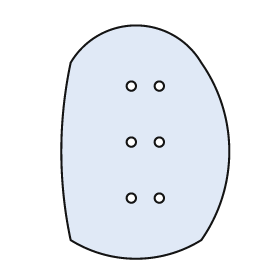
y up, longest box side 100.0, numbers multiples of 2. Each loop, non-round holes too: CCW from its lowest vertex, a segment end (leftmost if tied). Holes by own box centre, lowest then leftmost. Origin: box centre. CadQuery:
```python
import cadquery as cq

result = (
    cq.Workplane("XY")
    .moveTo(-32.0, -42.0)
    .threePointArc((-4.0, -50.0), (24.0, -42.0))
    .threePointArc((36.0, -4.0), (24.0, 34.0))
    .threePointArc((-4.0, 50.0), (-32.0, 34.0))
    .threePointArc((-36.0, -4.0), (-32.0, -42.0))
    .close()
    .moveTo(-6.0, -24.0)
    .circle(2.0)
    .moveTo(6.0, -24.0)
    .circle(2.0)
    .moveTo(-6.0, 0.0)
    .circle(2.0)
    .moveTo(6.0, 0.0)
    .circle(2.0)
    .moveTo(-6.0, 24.0)
    .circle(2.0)
    .moveTo(6.0, 24.0)
    .circle(2.0)
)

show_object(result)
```